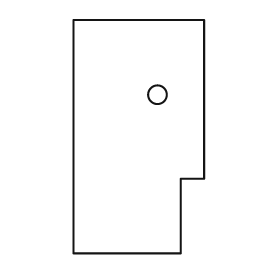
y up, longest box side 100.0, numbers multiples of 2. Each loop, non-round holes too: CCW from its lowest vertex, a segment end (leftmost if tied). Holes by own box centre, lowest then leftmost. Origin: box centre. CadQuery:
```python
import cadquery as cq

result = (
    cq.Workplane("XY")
    .moveTo(-28.0, -50.0)
    .lineTo(18.0, -50.0)
    .lineTo(18.0, -18.0)
    .lineTo(28.0, -18.0)
    .lineTo(28.0, 50.0)
    .lineTo(-28.0, 50.0)
    .close()
    .moveTo(8.0, 18.0)
    .circle(4.0)
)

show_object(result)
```